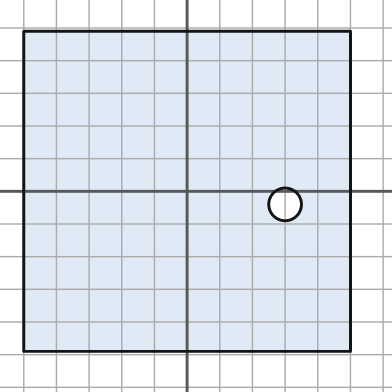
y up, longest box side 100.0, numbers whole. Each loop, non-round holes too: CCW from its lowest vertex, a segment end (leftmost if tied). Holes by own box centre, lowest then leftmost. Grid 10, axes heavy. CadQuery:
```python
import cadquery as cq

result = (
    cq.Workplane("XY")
    .moveTo(-50.0, -49.0)
    .lineTo(50.0, -49.0)
    .lineTo(50.0, 49.0)
    .lineTo(-50.0, 49.0)
    .close()
    .moveTo(30.0, -4.0)
    .circle(5.0)
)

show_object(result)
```